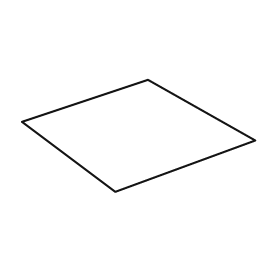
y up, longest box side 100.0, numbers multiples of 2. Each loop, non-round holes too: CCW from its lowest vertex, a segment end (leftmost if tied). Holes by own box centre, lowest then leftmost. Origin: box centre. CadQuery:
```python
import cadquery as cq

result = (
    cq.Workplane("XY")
    .moveTo(-10.0, -24.0)
    .lineTo(50.0, -2.0)
    .lineTo(4.0, 24.0)
    .lineTo(-50.0, 6.0)
    .close()
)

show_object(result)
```